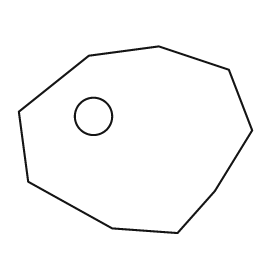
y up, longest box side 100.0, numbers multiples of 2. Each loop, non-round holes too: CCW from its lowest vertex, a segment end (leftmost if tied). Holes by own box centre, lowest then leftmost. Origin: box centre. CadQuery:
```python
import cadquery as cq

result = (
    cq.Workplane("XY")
    .moveTo(18.0, -40.0)
    .lineTo(34.0, -22.0)
    .lineTo(50.0, 4.0)
    .lineTo(40.0, 30.0)
    .lineTo(10.0, 40.0)
    .lineTo(-20.0, 36.0)
    .lineTo(-50.0, 12.0)
    .lineTo(-46.0, -18.0)
    .lineTo(-10.0, -38.0)
    .close()
    .moveTo(-18.0, 10.0)
    .circle(8.0)
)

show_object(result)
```